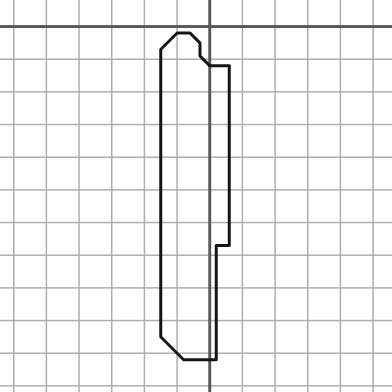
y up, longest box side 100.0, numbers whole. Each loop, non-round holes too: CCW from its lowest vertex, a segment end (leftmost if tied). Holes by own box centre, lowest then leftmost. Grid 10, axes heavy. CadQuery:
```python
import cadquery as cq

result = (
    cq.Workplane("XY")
    .moveTo(-8.0, -102.0)
    .lineTo(2.0, -102.0)
    .lineTo(2.0, -67.0)
    .lineTo(6.0, -67.0)
    .lineTo(6.0, -12.0)
    .lineTo(0.0, -12.0)
    .lineTo(-3.0, -9.0)
    .lineTo(-3.0, -5.0)
    .lineTo(-6.0, -2.0)
    .lineTo(-10.0, -2.0)
    .lineTo(-15.0, -7.0)
    .lineTo(-15.0, -95.0)
    .close()
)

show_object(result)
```